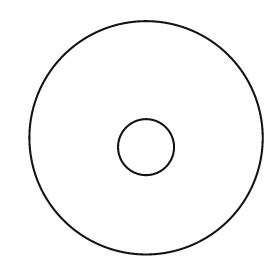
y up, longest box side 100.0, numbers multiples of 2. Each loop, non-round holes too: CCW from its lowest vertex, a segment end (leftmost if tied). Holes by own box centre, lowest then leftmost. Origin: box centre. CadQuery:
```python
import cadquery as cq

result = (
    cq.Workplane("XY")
    .moveTo(0.0, 0.0)
    .circle(50.0)
    .moveTo(0.0, -4.0)
    .circle(12.0)
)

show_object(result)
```